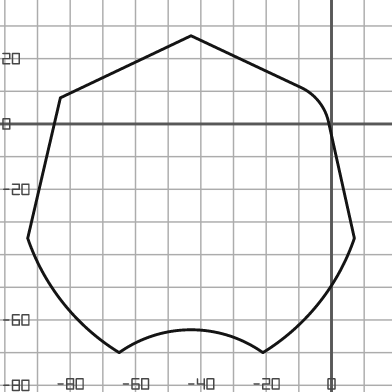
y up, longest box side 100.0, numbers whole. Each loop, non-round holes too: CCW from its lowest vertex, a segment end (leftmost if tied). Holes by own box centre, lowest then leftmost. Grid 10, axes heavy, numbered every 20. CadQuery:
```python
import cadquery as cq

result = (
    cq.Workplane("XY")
    .moveTo(-65.0, -70.0)
    .threePointArc((-43.0, -63.0), (-21.0, -70.0))
    .threePointArc((-4.0, -55.0), (7.0, -35.0))
    .lineTo(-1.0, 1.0)
    .threePointArc((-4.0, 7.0), (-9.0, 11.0))
    .lineTo(-43.0, 27.0)
    .lineTo(-83.0, 8.0)
    .lineTo(-93.0, -35.0)
    .threePointArc((-82.0, -55.0), (-65.0, -70.0))
    .close()
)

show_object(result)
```